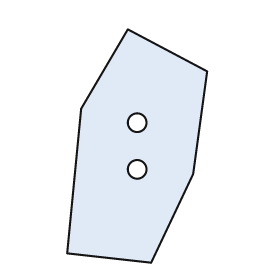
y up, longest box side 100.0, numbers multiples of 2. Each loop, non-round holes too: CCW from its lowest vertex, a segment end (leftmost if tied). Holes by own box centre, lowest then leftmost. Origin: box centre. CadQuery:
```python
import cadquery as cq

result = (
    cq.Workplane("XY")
    .moveTo(6.0, -50.0)
    .lineTo(24.0, -12.0)
    .lineTo(30.0, 32.0)
    .lineTo(-4.0, 50.0)
    .lineTo(-24.0, 16.0)
    .lineTo(-30.0, -46.0)
    .close()
    .moveTo(0.0, -10.0)
    .circle(4.0)
    .moveTo(0.0, 10.0)
    .circle(4.0)
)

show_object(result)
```